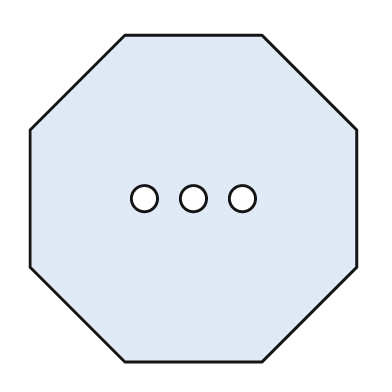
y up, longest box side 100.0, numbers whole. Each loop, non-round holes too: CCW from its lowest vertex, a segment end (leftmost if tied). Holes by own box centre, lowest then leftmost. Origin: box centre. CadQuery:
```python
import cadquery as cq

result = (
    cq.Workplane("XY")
    .moveTo(-21.0, -50.0)
    .lineTo(21.0, -50.0)
    .lineTo(50.0, -21.0)
    .lineTo(50.0, 21.0)
    .lineTo(21.0, 50.0)
    .lineTo(-21.0, 50.0)
    .lineTo(-50.0, 21.0)
    .lineTo(-50.0, -21.0)
    .close()
    .moveTo(-15.0, 0.0)
    .circle(4.0)
    .moveTo(0.0, 0.0)
    .circle(4.0)
    .moveTo(15.0, 0.0)
    .circle(4.0)
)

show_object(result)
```